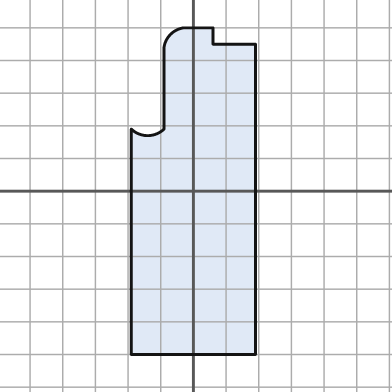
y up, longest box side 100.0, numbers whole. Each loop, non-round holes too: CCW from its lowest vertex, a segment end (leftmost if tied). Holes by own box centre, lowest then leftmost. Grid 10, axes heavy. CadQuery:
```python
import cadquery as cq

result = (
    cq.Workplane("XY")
    .moveTo(-19.0, -50.0)
    .lineTo(19.0, -50.0)
    .lineTo(19.0, 45.0)
    .lineTo(6.0, 45.0)
    .lineTo(6.0, 50.0)
    .lineTo(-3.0, 50.0)
    .threePointArc((-7.0, 48.0), (-9.0, 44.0))
    .lineTo(-9.0, 19.0)
    .threePointArc((-14.0, 17.0), (-19.0, 19.0))
    .close()
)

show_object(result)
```